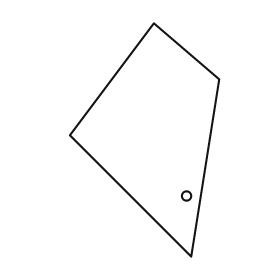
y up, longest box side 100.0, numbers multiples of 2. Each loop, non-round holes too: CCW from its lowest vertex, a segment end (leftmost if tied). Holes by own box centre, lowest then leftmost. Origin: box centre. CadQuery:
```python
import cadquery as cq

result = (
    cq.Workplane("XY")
    .moveTo(20.0, -50.0)
    .lineTo(32.0, 26.0)
    .lineTo(4.0, 50.0)
    .lineTo(-32.0, 2.0)
    .close()
    .moveTo(18.0, -24.0)
    .circle(2.0)
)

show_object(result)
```